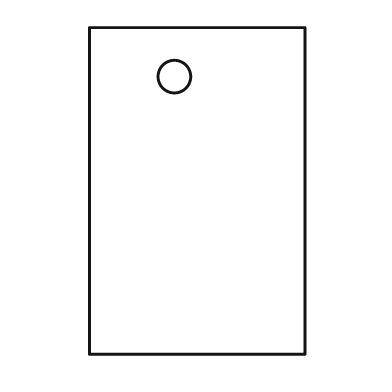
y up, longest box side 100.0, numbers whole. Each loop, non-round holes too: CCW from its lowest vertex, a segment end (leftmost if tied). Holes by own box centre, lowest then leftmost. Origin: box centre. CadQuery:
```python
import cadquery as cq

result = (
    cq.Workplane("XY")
    .moveTo(-33.0, -50.0)
    .lineTo(33.0, -50.0)
    .lineTo(33.0, 50.0)
    .lineTo(-33.0, 50.0)
    .close()
    .moveTo(-7.0, 35.0)
    .circle(5.0)
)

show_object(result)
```